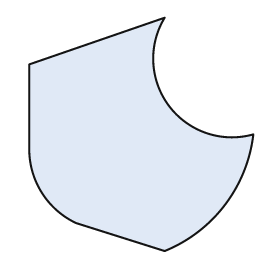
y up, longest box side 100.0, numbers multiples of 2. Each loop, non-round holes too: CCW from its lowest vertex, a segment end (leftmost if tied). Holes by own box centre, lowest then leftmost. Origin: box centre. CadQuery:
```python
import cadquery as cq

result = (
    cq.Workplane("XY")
    .moveTo(10.0, -50.0)
    .threePointArc((36.0, -30.0), (48.0, 0.0))
    .threePointArc((12.0, 12.0), (10.0, 50.0))
    .lineTo(-48.0, 30.0)
    .lineTo(-48.0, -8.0)
    .threePointArc((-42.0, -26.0), (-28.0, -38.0))
    .close()
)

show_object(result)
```